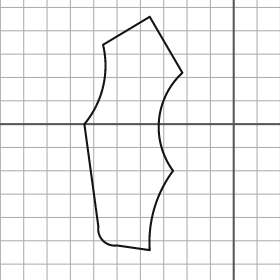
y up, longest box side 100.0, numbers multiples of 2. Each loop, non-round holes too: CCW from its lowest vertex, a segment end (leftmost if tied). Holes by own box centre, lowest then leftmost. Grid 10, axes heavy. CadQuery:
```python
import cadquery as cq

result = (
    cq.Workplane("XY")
    .moveTo(-36.0, -54.0)
    .threePointArc((-34.0, -36.0), (-26.0, -20.0))
    .threePointArc((-32.0, 2.0), (-22.0, 22.0))
    .lineTo(-36.0, 46.0)
    .lineTo(-56.0, 34.0)
    .threePointArc((-56.0, 16.0), (-64.0, 0.0))
    .lineTo(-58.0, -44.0)
    .threePointArc((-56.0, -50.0), (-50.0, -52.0))
    .close()
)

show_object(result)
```